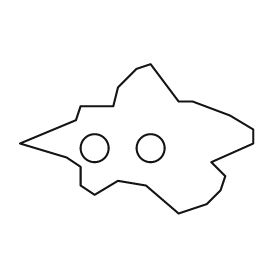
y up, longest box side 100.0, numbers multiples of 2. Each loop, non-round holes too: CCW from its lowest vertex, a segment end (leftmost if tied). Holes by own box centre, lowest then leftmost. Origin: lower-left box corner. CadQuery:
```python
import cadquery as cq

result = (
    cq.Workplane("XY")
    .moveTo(68.0, 0.0)
    .lineTo(80.0, 4.0)
    .lineTo(86.0, 10.0)
    .lineTo(88.0, 16.0)
    .lineTo(82.0, 22.0)
    .lineTo(100.0, 30.0)
    .lineTo(100.0, 36.0)
    .lineTo(90.0, 42.0)
    .lineTo(74.0, 48.0)
    .lineTo(68.0, 48.0)
    .lineTo(56.0, 64.0)
    .lineTo(50.0, 62.0)
    .lineTo(42.0, 54.0)
    .lineTo(40.0, 46.0)
    .lineTo(26.0, 46.0)
    .lineTo(24.0, 40.0)
    .lineTo(0.0, 30.0)
    .lineTo(20.0, 24.0)
    .lineTo(26.0, 20.0)
    .lineTo(26.0, 12.0)
    .lineTo(32.0, 8.0)
    .lineTo(42.0, 14.0)
    .lineTo(54.0, 12.0)
    .close()
    .moveTo(32.0, 28.0)
    .circle(6.0)
    .moveTo(56.0, 28.0)
    .circle(6.0)
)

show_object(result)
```